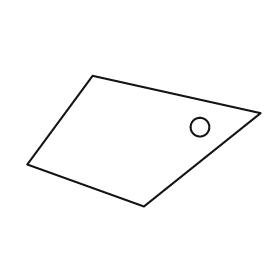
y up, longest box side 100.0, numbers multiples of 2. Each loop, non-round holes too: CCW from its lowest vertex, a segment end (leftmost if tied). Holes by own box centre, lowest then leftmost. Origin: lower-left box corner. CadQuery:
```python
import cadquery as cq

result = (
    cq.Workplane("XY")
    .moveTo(50.0, 0.0)
    .lineTo(100.0, 40.0)
    .lineTo(28.0, 56.0)
    .lineTo(0.0, 18.0)
    .close()
    .moveTo(74.0, 34.0)
    .circle(4.0)
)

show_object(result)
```